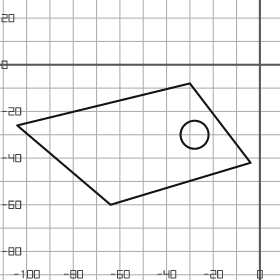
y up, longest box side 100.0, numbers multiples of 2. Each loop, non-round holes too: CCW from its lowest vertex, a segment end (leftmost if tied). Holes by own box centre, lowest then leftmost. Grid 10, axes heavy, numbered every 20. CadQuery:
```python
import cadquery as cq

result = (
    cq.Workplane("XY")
    .moveTo(-64.0, -60.0)
    .lineTo(-4.0, -42.0)
    .lineTo(-30.0, -8.0)
    .lineTo(-104.0, -26.0)
    .close()
    .moveTo(-28.0, -30.0)
    .circle(6.0)
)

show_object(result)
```